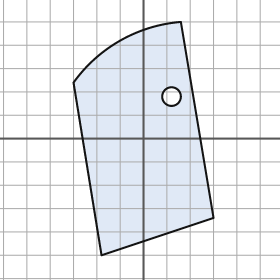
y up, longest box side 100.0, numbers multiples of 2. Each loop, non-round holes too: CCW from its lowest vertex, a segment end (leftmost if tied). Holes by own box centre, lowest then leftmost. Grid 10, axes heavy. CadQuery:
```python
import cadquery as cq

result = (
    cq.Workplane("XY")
    .moveTo(-18.0, -50.0)
    .lineTo(30.0, -34.0)
    .lineTo(16.0, 50.0)
    .threePointArc((-10.0, 42.0), (-30.0, 24.0))
    .close()
    .moveTo(12.0, 18.0)
    .circle(4.0)
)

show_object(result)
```